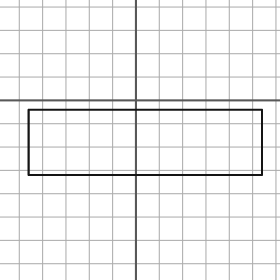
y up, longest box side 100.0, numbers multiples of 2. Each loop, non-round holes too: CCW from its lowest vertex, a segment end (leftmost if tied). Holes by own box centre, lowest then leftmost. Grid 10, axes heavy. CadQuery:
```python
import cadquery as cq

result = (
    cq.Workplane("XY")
    .moveTo(-46.0, -32.0)
    .lineTo(54.0, -32.0)
    .lineTo(54.0, -4.0)
    .lineTo(-46.0, -4.0)
    .close()
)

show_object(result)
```